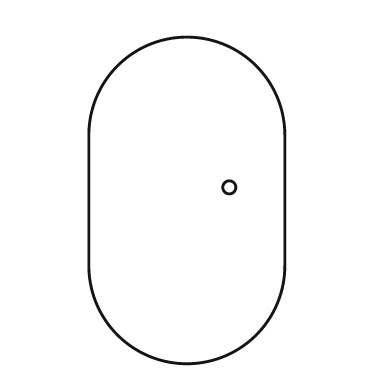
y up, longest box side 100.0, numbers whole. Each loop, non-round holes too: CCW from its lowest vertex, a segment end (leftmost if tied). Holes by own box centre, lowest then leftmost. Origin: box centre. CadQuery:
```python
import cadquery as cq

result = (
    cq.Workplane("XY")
    .moveTo(-30.0, -20.0)
    .threePointArc((0.0, -50.0), (30.0, -20.0))
    .lineTo(30.0, 20.0)
    .threePointArc((0.0, 50.0), (-30.0, 20.0))
    .close()
    .moveTo(13.0, 4.0)
    .circle(2.0)
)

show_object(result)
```